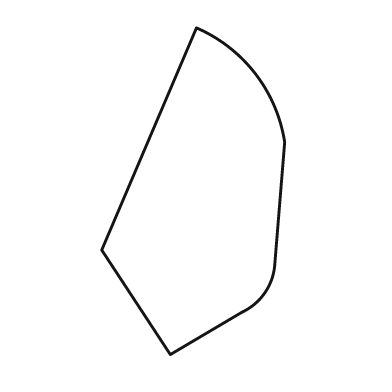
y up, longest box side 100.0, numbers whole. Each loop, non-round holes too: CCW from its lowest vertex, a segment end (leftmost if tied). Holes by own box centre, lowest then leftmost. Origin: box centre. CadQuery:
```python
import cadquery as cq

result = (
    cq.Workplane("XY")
    .moveTo(-7.0, -50.0)
    .lineTo(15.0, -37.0)
    .threePointArc((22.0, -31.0), (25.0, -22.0))
    .lineTo(28.0, 15.0)
    .threePointArc((19.0, 36.0), (1.0, 50.0))
    .lineTo(-28.0, -18.0)
    .close()
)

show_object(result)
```